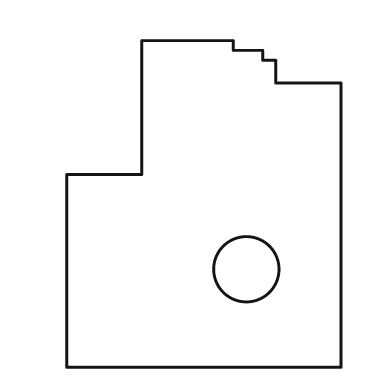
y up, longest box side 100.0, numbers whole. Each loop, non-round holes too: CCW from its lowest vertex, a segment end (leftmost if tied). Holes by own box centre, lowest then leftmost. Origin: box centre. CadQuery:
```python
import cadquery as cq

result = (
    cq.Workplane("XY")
    .moveTo(-42.0, -50.0)
    .lineTo(42.0, -50.0)
    .lineTo(42.0, 37.0)
    .lineTo(22.0, 37.0)
    .lineTo(22.0, 44.0)
    .lineTo(18.0, 44.0)
    .lineTo(18.0, 47.0)
    .lineTo(9.0, 47.0)
    .lineTo(9.0, 50.0)
    .lineTo(-19.0, 50.0)
    .lineTo(-19.0, 9.0)
    .lineTo(-42.0, 9.0)
    .close()
    .moveTo(13.0, -20.0)
    .circle(10.0)
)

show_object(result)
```